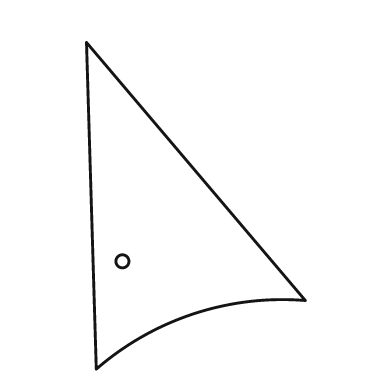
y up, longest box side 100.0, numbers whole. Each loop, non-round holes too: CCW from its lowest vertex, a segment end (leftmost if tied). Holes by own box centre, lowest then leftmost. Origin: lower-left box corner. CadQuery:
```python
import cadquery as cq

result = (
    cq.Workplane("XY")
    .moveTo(3.0, 0.0)
    .threePointArc((33.0, 17.0), (67.0, 21.0))
    .lineTo(0.0, 100.0)
    .close()
    .moveTo(11.0, 33.0)
    .circle(2.0)
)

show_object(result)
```